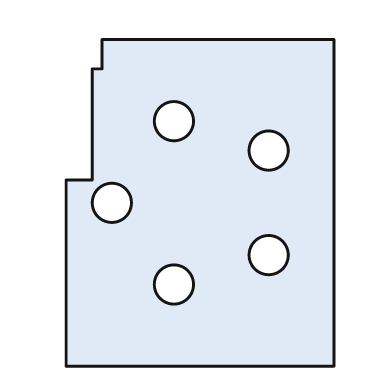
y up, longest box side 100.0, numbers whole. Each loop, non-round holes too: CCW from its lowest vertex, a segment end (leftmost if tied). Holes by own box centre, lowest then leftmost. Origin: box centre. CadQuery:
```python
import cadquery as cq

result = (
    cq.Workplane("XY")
    .moveTo(-41.0, -50.0)
    .lineTo(41.0, -50.0)
    .lineTo(41.0, 50.0)
    .lineTo(-30.0, 50.0)
    .lineTo(-30.0, 41.0)
    .lineTo(-33.0, 41.0)
    .lineTo(-33.0, 7.0)
    .lineTo(-41.0, 7.0)
    .close()
    .moveTo(-8.0, -25.0)
    .circle(6.0)
    .moveTo(21.0, -16.0)
    .circle(6.0)
    .moveTo(-27.0, 0.0)
    .circle(6.0)
    .moveTo(21.0, 16.0)
    .circle(6.0)
    .moveTo(-8.0, 25.0)
    .circle(6.0)
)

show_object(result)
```